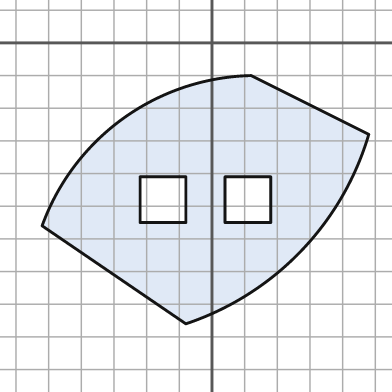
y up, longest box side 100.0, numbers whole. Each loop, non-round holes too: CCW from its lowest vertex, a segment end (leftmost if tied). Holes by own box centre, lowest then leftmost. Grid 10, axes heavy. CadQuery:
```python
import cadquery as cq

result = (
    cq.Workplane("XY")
    .moveTo(-8.0, -86.0)
    .threePointArc((27.0, -64.0), (48.0, -28.0))
    .lineTo(12.0, -10.0)
    .threePointArc((-27.0, -23.0), (-52.0, -56.0))
    .close()
    .moveTo(-22.0, -55.0)
    .lineTo(-8.0, -55.0)
    .lineTo(-8.0, -41.0)
    .lineTo(-22.0, -41.0)
    .close()
    .moveTo(4.0, -55.0)
    .lineTo(18.0, -55.0)
    .lineTo(18.0, -41.0)
    .lineTo(4.0, -41.0)
    .close()
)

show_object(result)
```